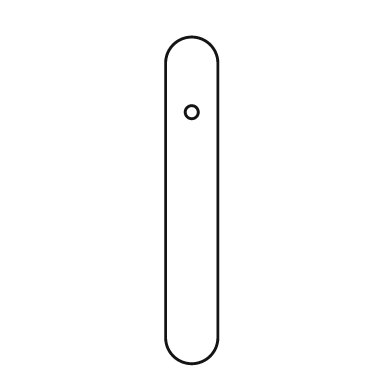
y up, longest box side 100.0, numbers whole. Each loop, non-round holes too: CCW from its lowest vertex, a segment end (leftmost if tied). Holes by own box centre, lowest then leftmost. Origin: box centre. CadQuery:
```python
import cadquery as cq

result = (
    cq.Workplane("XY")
    .moveTo(-8.0, -42.0)
    .threePointArc((0.0, -50.0), (8.0, -42.0))
    .lineTo(8.0, 42.0)
    .threePointArc((0.0, 50.0), (-8.0, 42.0))
    .close()
    .moveTo(0.0, 27.0)
    .circle(2.0)
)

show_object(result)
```